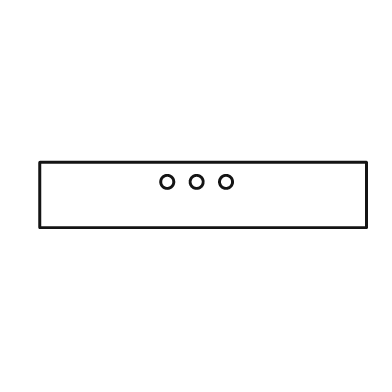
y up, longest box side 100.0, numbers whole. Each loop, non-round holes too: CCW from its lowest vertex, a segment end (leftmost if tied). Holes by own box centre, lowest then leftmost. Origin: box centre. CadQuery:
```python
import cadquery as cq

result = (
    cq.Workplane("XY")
    .moveTo(-50.0, -10.0)
    .lineTo(50.0, -10.0)
    .lineTo(50.0, 10.0)
    .lineTo(-50.0, 10.0)
    .close()
    .moveTo(-11.0, 4.0)
    .circle(2.0)
    .moveTo(-2.0, 4.0)
    .circle(2.0)
    .moveTo(7.0, 4.0)
    .circle(2.0)
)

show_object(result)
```